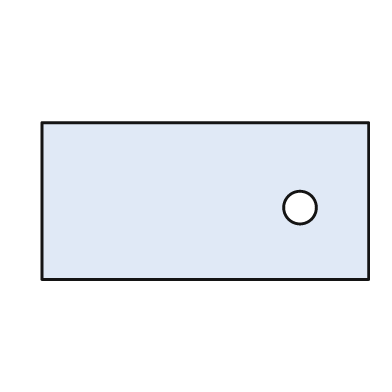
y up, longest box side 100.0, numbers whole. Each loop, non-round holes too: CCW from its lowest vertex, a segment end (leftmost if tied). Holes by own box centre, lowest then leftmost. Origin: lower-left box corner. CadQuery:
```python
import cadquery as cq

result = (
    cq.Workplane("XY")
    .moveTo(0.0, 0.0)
    .lineTo(100.0, 0.0)
    .lineTo(100.0, 48.0)
    .lineTo(0.0, 48.0)
    .close()
    .moveTo(79.0, 22.0)
    .circle(5.0)
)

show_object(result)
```